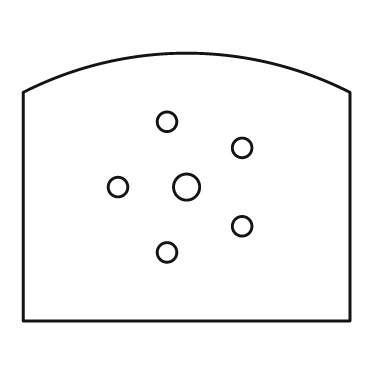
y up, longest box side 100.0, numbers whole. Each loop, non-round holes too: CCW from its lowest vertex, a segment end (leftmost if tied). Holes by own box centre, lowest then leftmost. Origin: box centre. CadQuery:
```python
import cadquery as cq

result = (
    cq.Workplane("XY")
    .moveTo(-50.0, -41.0)
    .lineTo(50.0, -41.0)
    .lineTo(50.0, 29.0)
    .threePointArc((0.0, 41.0), (-50.0, 29.0))
    .close()
    .moveTo(-6.0, -20.0)
    .circle(3.0)
    .moveTo(17.0, -12.0)
    .circle(3.0)
    .moveTo(-21.0, 0.0)
    .circle(3.0)
    .moveTo(0.0, 0.0)
    .circle(4.0)
    .moveTo(17.0, 12.0)
    .circle(3.0)
    .moveTo(-6.0, 20.0)
    .circle(3.0)
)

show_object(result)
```